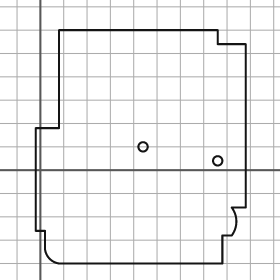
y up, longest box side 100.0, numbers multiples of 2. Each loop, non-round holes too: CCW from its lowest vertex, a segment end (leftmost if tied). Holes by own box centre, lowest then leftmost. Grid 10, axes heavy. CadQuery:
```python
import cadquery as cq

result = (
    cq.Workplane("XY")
    .moveTo(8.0, -40.0)
    .lineTo(78.0, -40.0)
    .lineTo(78.0, -28.0)
    .lineTo(82.0, -28.0)
    .threePointArc((84.0, -22.0), (82.0, -16.0))
    .lineTo(88.0, -16.0)
    .lineTo(88.0, 54.0)
    .lineTo(76.0, 54.0)
    .lineTo(76.0, 60.0)
    .lineTo(8.0, 60.0)
    .lineTo(8.0, 18.0)
    .lineTo(-2.0, 18.0)
    .lineTo(-2.0, -26.0)
    .lineTo(2.0, -26.0)
    .lineTo(2.0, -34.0)
    .threePointArc((4.0, -38.0), (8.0, -40.0))
    .close()
    .moveTo(76.0, 4.0)
    .circle(2.0)
    .moveTo(44.0, 10.0)
    .circle(2.0)
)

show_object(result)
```